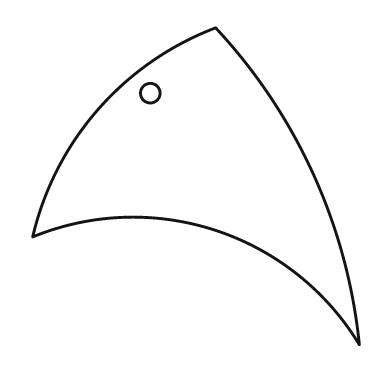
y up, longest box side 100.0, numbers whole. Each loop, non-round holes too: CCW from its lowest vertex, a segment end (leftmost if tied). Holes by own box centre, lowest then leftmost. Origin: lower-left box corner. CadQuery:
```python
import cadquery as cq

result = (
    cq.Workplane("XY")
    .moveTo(100.0, 0.0)
    .threePointArc((86.0, 52.0), (56.0, 97.0))
    .threePointArc((20.0, 72.0), (0.0, 33.0))
    .threePointArc((56.0, 35.0), (100.0, 0.0))
    .close()
    .moveTo(36.0, 77.0)
    .circle(3.0)
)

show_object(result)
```